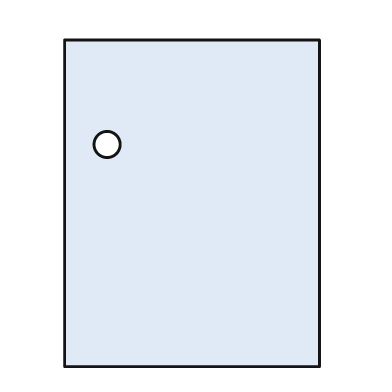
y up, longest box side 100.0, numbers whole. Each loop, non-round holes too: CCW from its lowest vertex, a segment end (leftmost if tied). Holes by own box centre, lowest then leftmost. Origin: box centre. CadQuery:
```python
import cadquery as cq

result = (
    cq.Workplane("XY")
    .moveTo(-39.0, -50.0)
    .lineTo(39.0, -50.0)
    .lineTo(39.0, 50.0)
    .lineTo(-39.0, 50.0)
    .close()
    .moveTo(-26.0, 18.0)
    .circle(4.0)
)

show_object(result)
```